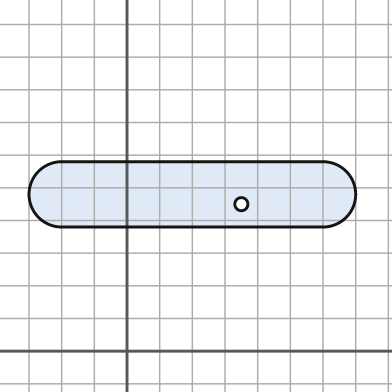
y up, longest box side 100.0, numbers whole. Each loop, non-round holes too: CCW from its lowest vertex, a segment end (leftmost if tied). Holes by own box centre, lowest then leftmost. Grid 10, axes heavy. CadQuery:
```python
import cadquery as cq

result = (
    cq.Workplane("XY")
    .moveTo(-20.0, 38.0)
    .lineTo(60.0, 38.0)
    .threePointArc((70.0, 48.0), (60.0, 58.0))
    .lineTo(-20.0, 58.0)
    .threePointArc((-30.0, 48.0), (-20.0, 38.0))
    .close()
    .moveTo(35.0, 45.0)
    .circle(2.0)
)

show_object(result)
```